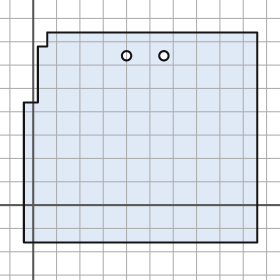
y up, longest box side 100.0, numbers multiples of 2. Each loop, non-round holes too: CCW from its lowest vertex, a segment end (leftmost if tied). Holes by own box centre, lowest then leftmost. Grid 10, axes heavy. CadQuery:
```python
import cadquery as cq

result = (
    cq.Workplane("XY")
    .moveTo(-4.0, -16.0)
    .lineTo(96.0, -16.0)
    .lineTo(96.0, 74.0)
    .lineTo(6.0, 74.0)
    .lineTo(6.0, 68.0)
    .lineTo(2.0, 68.0)
    .lineTo(2.0, 44.0)
    .lineTo(-4.0, 44.0)
    .close()
    .moveTo(40.0, 64.0)
    .circle(2.0)
    .moveTo(56.0, 64.0)
    .circle(2.0)
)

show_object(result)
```